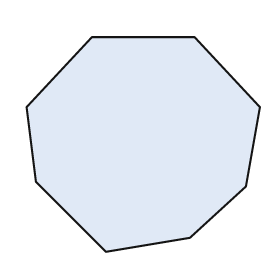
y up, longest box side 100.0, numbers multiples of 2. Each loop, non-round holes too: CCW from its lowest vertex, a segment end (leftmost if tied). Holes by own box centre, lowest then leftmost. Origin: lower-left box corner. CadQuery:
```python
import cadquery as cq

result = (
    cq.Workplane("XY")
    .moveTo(34.0, 0.0)
    .lineTo(70.0, 6.0)
    .lineTo(94.0, 28.0)
    .lineTo(100.0, 62.0)
    .lineTo(72.0, 92.0)
    .lineTo(28.0, 92.0)
    .lineTo(0.0, 62.0)
    .lineTo(4.0, 30.0)
    .close()
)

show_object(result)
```